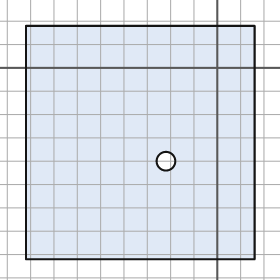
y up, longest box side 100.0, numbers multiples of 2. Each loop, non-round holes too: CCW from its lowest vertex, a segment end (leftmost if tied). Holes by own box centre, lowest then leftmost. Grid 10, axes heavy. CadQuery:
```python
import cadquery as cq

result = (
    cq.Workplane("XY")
    .moveTo(-82.0, -82.0)
    .lineTo(16.0, -82.0)
    .lineTo(16.0, 18.0)
    .lineTo(-82.0, 18.0)
    .close()
    .moveTo(-22.0, -40.0)
    .circle(4.0)
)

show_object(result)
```